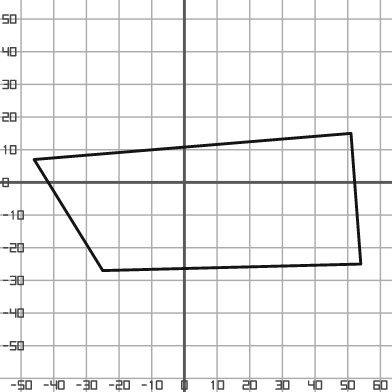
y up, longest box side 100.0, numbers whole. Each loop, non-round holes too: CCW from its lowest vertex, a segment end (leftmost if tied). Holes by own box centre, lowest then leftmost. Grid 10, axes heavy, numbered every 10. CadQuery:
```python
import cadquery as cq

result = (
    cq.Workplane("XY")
    .moveTo(-25.0, -27.0)
    .lineTo(54.0, -25.0)
    .lineTo(51.0, 15.0)
    .lineTo(-46.0, 7.0)
    .close()
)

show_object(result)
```